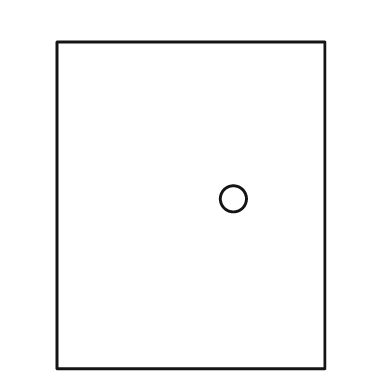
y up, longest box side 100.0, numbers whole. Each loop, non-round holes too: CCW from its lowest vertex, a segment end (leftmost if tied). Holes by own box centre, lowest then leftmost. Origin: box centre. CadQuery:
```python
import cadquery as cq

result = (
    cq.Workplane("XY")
    .moveTo(-41.0, -50.0)
    .lineTo(41.0, -50.0)
    .lineTo(41.0, 50.0)
    .lineTo(-41.0, 50.0)
    .close()
    .moveTo(13.0, 2.0)
    .circle(4.0)
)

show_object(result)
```